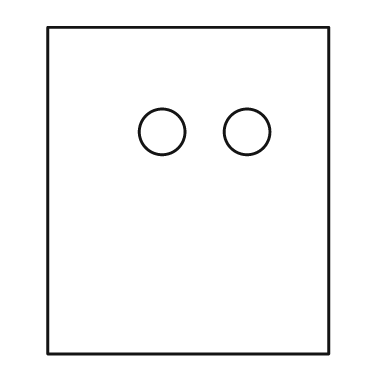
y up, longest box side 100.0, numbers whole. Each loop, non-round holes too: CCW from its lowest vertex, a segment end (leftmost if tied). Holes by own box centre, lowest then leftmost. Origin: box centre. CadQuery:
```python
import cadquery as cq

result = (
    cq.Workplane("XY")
    .moveTo(-43.0, -50.0)
    .lineTo(43.0, -50.0)
    .lineTo(43.0, 50.0)
    .lineTo(-43.0, 50.0)
    .close()
    .moveTo(-8.0, 18.0)
    .circle(7.0)
    .moveTo(18.0, 18.0)
    .circle(7.0)
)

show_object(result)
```